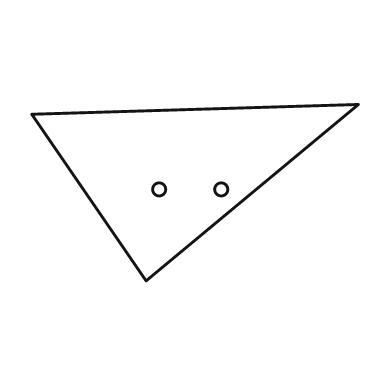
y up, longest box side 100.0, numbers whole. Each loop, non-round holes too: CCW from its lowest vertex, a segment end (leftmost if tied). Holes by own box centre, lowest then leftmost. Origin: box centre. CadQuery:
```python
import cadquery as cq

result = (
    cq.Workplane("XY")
    .moveTo(-15.0, -27.0)
    .lineTo(50.0, 27.0)
    .lineTo(-50.0, 24.0)
    .close()
    .moveTo(-11.0, 1.0)
    .circle(2.0)
    .moveTo(8.0, 1.0)
    .circle(2.0)
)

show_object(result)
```